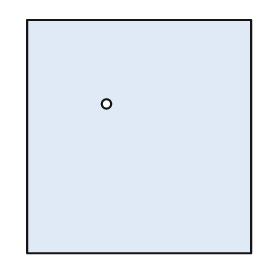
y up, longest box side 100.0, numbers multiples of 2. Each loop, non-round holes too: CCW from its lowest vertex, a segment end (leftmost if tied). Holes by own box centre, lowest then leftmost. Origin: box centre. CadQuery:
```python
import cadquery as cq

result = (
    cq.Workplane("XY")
    .moveTo(-48.0, -50.0)
    .lineTo(48.0, -50.0)
    .lineTo(48.0, 50.0)
    .lineTo(-48.0, 50.0)
    .close()
    .moveTo(-14.0, 14.0)
    .circle(2.0)
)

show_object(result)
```